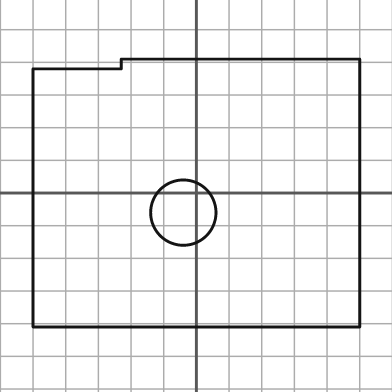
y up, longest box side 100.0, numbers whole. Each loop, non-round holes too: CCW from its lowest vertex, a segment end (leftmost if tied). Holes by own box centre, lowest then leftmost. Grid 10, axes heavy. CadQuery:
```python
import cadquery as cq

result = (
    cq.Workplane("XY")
    .moveTo(-50.0, -41.0)
    .lineTo(50.0, -41.0)
    .lineTo(50.0, 41.0)
    .lineTo(-23.0, 41.0)
    .lineTo(-23.0, 38.0)
    .lineTo(-50.0, 38.0)
    .close()
    .moveTo(-4.0, -6.0)
    .circle(10.0)
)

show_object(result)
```